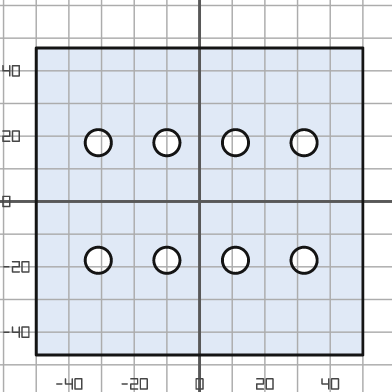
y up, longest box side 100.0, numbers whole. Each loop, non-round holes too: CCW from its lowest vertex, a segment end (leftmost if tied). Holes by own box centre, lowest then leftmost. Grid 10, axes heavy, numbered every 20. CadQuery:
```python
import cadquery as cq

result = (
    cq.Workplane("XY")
    .moveTo(-50.0, -47.0)
    .lineTo(50.0, -47.0)
    .lineTo(50.0, 47.0)
    .lineTo(-50.0, 47.0)
    .close()
    .moveTo(-31.0, -18.0)
    .circle(4.0)
    .moveTo(-10.0, -18.0)
    .circle(4.0)
    .moveTo(11.0, -18.0)
    .circle(4.0)
    .moveTo(32.0, -18.0)
    .circle(4.0)
    .moveTo(-31.0, 18.0)
    .circle(4.0)
    .moveTo(-10.0, 18.0)
    .circle(4.0)
    .moveTo(11.0, 18.0)
    .circle(4.0)
    .moveTo(32.0, 18.0)
    .circle(4.0)
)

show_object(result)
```